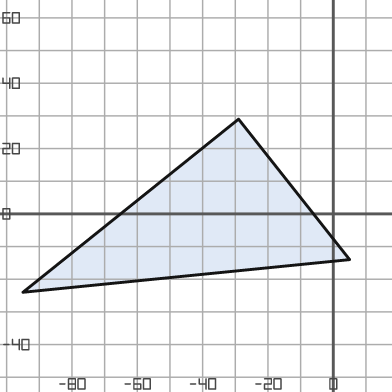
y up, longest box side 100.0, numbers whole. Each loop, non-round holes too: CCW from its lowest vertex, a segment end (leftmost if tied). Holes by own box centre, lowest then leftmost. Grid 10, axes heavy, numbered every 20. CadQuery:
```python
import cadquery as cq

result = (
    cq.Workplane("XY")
    .moveTo(-95.0, -24.0)
    .lineTo(5.0, -14.0)
    .lineTo(-29.0, 29.0)
    .close()
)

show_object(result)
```